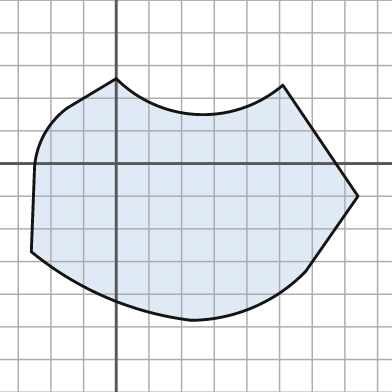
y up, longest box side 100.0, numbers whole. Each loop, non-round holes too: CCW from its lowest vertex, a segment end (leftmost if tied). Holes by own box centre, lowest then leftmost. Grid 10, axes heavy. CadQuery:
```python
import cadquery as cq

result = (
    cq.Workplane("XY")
    .moveTo(23.0, -48.0)
    .threePointArc((42.0, -44.0), (58.0, -33.0))
    .lineTo(74.0, -10.0)
    .lineTo(51.0, 24.0)
    .threePointArc((25.0, 15.0), (0.0, 26.0))
    .lineTo(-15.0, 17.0)
    .threePointArc((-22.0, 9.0), (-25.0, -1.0))
    .lineTo(-26.0, -27.0)
    .threePointArc((-3.0, -41.0), (23.0, -48.0))
    .close()
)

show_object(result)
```